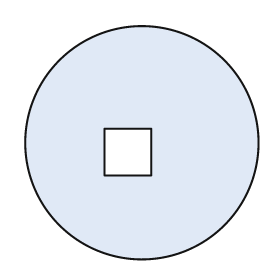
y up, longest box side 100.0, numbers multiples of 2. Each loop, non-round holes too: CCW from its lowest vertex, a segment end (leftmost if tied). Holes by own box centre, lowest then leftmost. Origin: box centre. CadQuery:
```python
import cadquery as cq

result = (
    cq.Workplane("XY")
    .moveTo(0.0, 0.0)
    .circle(50.0)
    .moveTo(-16.0, -14.0)
    .lineTo(4.0, -14.0)
    .lineTo(4.0, 6.0)
    .lineTo(-16.0, 6.0)
    .close()
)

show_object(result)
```